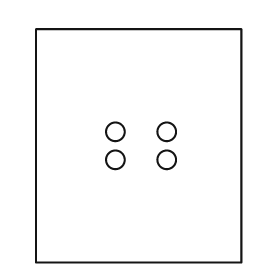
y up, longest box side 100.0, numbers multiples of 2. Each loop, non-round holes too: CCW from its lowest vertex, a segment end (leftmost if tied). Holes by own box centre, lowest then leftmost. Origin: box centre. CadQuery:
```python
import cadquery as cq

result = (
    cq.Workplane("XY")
    .moveTo(-44.0, -50.0)
    .lineTo(44.0, -50.0)
    .lineTo(44.0, 50.0)
    .lineTo(-44.0, 50.0)
    .close()
    .moveTo(-10.0, -6.0)
    .circle(4.0)
    .moveTo(12.0, -6.0)
    .circle(4.0)
    .moveTo(-10.0, 6.0)
    .circle(4.0)
    .moveTo(12.0, 6.0)
    .circle(4.0)
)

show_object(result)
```